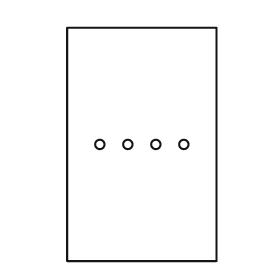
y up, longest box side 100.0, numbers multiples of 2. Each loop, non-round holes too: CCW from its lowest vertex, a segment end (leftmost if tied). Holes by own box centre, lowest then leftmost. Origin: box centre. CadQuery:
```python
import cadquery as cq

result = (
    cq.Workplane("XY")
    .moveTo(-32.0, -50.0)
    .lineTo(32.0, -50.0)
    .lineTo(32.0, 50.0)
    .lineTo(-32.0, 50.0)
    .close()
    .moveTo(-18.0, 0.0)
    .circle(2.0)
    .moveTo(-6.0, 0.0)
    .circle(2.0)
    .moveTo(6.0, 0.0)
    .circle(2.0)
    .moveTo(18.0, 0.0)
    .circle(2.0)
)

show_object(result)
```